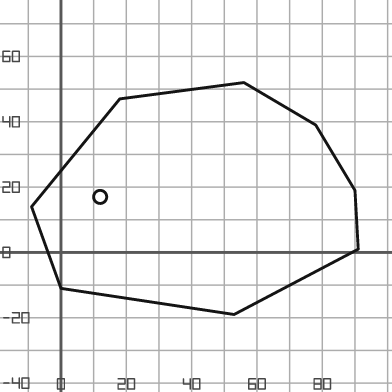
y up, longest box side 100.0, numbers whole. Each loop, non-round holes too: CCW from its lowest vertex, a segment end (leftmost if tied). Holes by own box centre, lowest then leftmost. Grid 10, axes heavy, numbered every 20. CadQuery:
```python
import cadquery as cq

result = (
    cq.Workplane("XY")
    .moveTo(53.0, -19.0)
    .lineTo(91.0, 1.0)
    .lineTo(90.0, 19.0)
    .lineTo(78.0, 39.0)
    .lineTo(56.0, 52.0)
    .lineTo(18.0, 47.0)
    .lineTo(-9.0, 14.0)
    .lineTo(0.0, -11.0)
    .close()
    .moveTo(12.0, 17.0)
    .circle(2.0)
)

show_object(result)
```